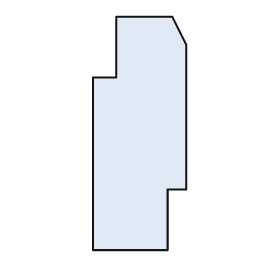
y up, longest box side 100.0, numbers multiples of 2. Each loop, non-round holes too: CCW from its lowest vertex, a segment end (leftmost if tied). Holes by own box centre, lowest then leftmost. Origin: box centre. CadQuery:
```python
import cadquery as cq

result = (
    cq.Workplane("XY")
    .moveTo(-20.0, -50.0)
    .lineTo(12.0, -50.0)
    .lineTo(12.0, -24.0)
    .lineTo(20.0, -24.0)
    .lineTo(20.0, 38.0)
    .lineTo(14.0, 50.0)
    .lineTo(-10.0, 50.0)
    .lineTo(-10.0, 24.0)
    .lineTo(-20.0, 24.0)
    .close()
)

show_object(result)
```